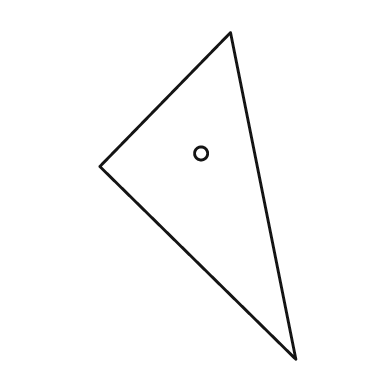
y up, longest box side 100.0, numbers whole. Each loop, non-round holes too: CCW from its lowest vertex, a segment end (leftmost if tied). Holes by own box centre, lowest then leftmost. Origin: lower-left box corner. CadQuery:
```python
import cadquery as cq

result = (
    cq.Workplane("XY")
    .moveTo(60.0, 0.0)
    .lineTo(40.0, 100.0)
    .lineTo(0.0, 59.0)
    .close()
    .moveTo(31.0, 63.0)
    .circle(2.0)
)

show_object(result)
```